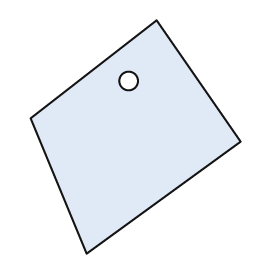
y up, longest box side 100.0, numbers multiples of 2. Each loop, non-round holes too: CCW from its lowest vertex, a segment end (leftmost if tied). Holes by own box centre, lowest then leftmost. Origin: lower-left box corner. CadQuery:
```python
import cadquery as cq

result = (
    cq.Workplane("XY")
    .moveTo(24.0, 0.0)
    .lineTo(90.0, 48.0)
    .lineTo(54.0, 100.0)
    .lineTo(0.0, 58.0)
    .close()
    .moveTo(42.0, 74.0)
    .circle(4.0)
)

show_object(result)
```